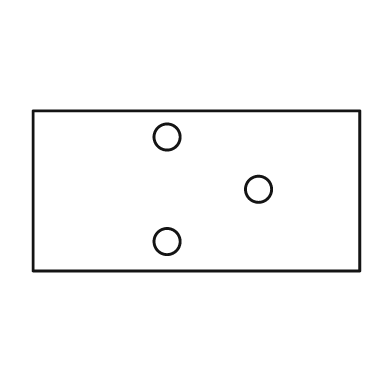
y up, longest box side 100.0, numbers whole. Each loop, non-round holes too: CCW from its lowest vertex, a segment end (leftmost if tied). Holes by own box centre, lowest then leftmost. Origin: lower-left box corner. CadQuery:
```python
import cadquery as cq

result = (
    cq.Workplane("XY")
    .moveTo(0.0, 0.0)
    .lineTo(100.0, 0.0)
    .lineTo(100.0, 49.0)
    .lineTo(0.0, 49.0)
    .close()
    .moveTo(41.0, 9.0)
    .circle(4.0)
    .moveTo(69.0, 25.0)
    .circle(4.0)
    .moveTo(41.0, 41.0)
    .circle(4.0)
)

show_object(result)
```